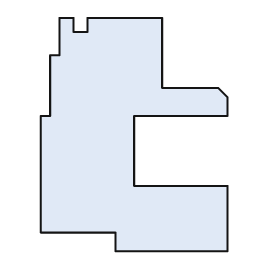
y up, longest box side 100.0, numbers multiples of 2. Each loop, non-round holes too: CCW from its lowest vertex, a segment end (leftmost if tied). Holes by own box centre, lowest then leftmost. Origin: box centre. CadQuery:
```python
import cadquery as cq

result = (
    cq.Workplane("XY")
    .moveTo(-8.0, -50.0)
    .lineTo(40.0, -50.0)
    .lineTo(40.0, -22.0)
    .lineTo(0.0, -22.0)
    .lineTo(0.0, 8.0)
    .lineTo(40.0, 8.0)
    .lineTo(40.0, 16.0)
    .lineTo(36.0, 20.0)
    .lineTo(12.0, 20.0)
    .lineTo(12.0, 50.0)
    .lineTo(-20.0, 50.0)
    .lineTo(-20.0, 44.0)
    .lineTo(-26.0, 44.0)
    .lineTo(-26.0, 50.0)
    .lineTo(-32.0, 50.0)
    .lineTo(-32.0, 34.0)
    .lineTo(-36.0, 34.0)
    .lineTo(-36.0, 8.0)
    .lineTo(-40.0, 8.0)
    .lineTo(-40.0, -42.0)
    .lineTo(-8.0, -42.0)
    .close()
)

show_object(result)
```